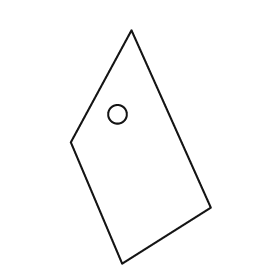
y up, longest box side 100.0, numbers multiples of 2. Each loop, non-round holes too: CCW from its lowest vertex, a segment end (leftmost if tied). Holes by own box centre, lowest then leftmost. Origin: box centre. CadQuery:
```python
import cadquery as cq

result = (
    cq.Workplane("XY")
    .moveTo(-8.0, -50.0)
    .lineTo(30.0, -26.0)
    .lineTo(-4.0, 50.0)
    .lineTo(-30.0, 2.0)
    .close()
    .moveTo(-10.0, 14.0)
    .circle(4.0)
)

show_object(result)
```